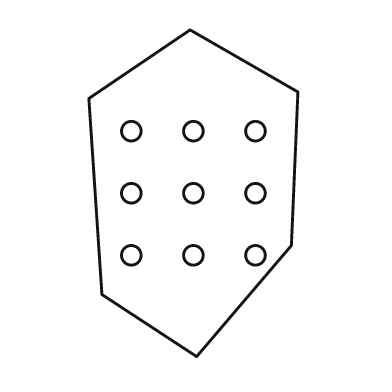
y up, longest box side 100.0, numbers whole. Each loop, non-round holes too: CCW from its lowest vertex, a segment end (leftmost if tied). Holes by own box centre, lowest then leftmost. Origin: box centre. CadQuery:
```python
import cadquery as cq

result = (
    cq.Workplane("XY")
    .moveTo(1.0, -50.0)
    .lineTo(30.0, -16.0)
    .lineTo(32.0, 31.0)
    .lineTo(-1.0, 50.0)
    .lineTo(-32.0, 29.0)
    .lineTo(-28.0, -31.0)
    .close()
    .moveTo(-19.0, -19.0)
    .circle(3.0)
    .moveTo(0.0, -19.0)
    .circle(3.0)
    .moveTo(19.0, -19.0)
    .circle(3.0)
    .moveTo(-19.0, 0.0)
    .circle(3.0)
    .moveTo(0.0, 0.0)
    .circle(3.0)
    .moveTo(19.0, 0.0)
    .circle(3.0)
    .moveTo(-19.0, 19.0)
    .circle(3.0)
    .moveTo(0.0, 19.0)
    .circle(3.0)
    .moveTo(19.0, 19.0)
    .circle(3.0)
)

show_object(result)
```